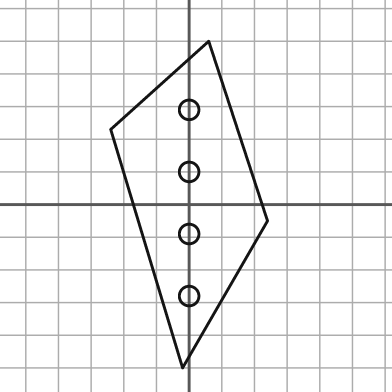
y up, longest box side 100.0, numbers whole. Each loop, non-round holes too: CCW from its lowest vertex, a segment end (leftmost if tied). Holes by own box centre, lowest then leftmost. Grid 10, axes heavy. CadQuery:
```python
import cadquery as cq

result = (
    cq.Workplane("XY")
    .moveTo(-2.0, -50.0)
    .lineTo(24.0, -5.0)
    .lineTo(6.0, 50.0)
    .lineTo(-24.0, 23.0)
    .close()
    .moveTo(0.0, -28.0)
    .circle(3.0)
    .moveTo(0.0, -9.0)
    .circle(3.0)
    .moveTo(0.0, 10.0)
    .circle(3.0)
    .moveTo(0.0, 29.0)
    .circle(3.0)
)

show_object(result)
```